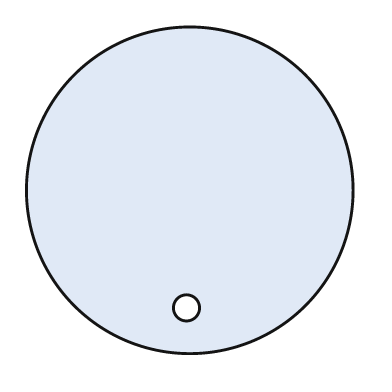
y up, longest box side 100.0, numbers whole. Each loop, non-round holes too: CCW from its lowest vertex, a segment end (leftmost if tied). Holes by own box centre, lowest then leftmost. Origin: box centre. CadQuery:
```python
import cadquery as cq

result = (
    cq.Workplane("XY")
    .moveTo(0.0, 0.0)
    .circle(50.0)
    .moveTo(-1.0, -36.0)
    .circle(4.0)
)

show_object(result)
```